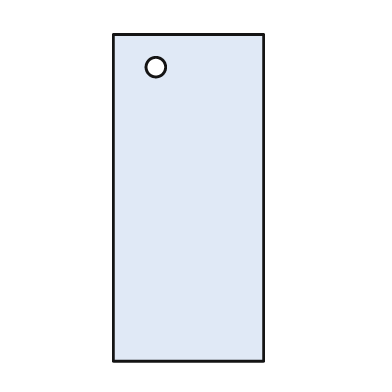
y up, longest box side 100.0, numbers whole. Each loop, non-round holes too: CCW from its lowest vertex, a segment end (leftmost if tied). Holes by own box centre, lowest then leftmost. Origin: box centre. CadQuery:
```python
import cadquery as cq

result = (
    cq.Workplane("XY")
    .moveTo(-23.0, -50.0)
    .lineTo(23.0, -50.0)
    .lineTo(23.0, 50.0)
    .lineTo(-23.0, 50.0)
    .close()
    .moveTo(-10.0, 40.0)
    .circle(3.0)
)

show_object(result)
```